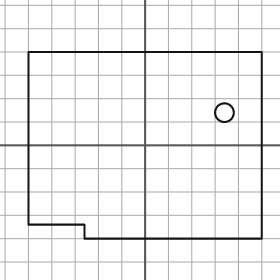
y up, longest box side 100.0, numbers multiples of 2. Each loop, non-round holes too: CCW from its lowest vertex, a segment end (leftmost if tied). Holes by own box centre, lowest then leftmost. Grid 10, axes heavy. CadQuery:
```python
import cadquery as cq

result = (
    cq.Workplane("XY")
    .moveTo(-26.0, -40.0)
    .lineTo(50.0, -40.0)
    .lineTo(50.0, 40.0)
    .lineTo(-50.0, 40.0)
    .lineTo(-50.0, -34.0)
    .lineTo(-26.0, -34.0)
    .close()
    .moveTo(34.0, 14.0)
    .circle(4.0)
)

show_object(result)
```